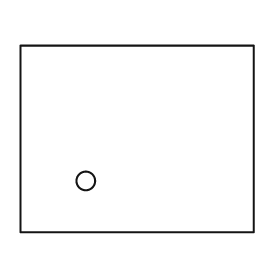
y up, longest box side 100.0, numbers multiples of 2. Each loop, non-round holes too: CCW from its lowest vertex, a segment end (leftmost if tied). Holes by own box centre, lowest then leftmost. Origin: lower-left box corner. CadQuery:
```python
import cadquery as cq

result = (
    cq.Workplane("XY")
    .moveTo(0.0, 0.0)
    .lineTo(100.0, 0.0)
    .lineTo(100.0, 80.0)
    .lineTo(0.0, 80.0)
    .close()
    .moveTo(28.0, 22.0)
    .circle(4.0)
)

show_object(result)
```